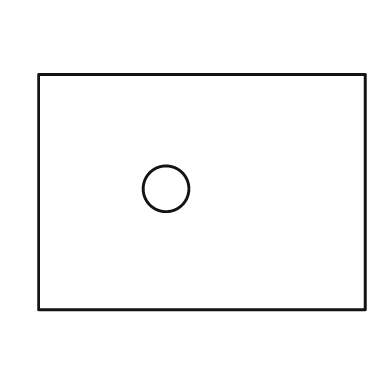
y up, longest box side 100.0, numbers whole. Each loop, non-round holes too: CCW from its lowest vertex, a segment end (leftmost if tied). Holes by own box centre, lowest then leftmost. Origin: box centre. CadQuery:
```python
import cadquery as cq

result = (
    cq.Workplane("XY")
    .moveTo(-50.0, -36.0)
    .lineTo(50.0, -36.0)
    .lineTo(50.0, 36.0)
    .lineTo(-50.0, 36.0)
    .close()
    .moveTo(-11.0, 1.0)
    .circle(7.0)
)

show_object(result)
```